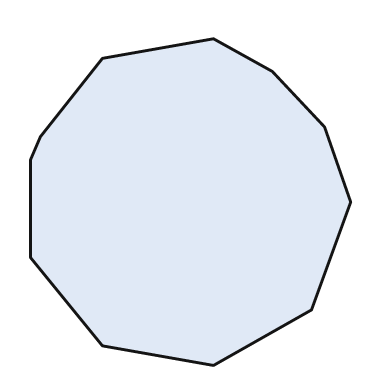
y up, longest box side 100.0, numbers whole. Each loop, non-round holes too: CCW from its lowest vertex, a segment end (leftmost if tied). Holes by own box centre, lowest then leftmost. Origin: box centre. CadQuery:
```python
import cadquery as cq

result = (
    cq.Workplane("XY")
    .moveTo(7.0, -50.0)
    .lineTo(37.0, -33.0)
    .lineTo(49.0, 0.0)
    .lineTo(41.0, 23.0)
    .lineTo(25.0, 40.0)
    .lineTo(7.0, 50.0)
    .lineTo(-27.0, 44.0)
    .lineTo(-46.0, 20.0)
    .lineTo(-49.0, 13.0)
    .lineTo(-49.0, -17.0)
    .lineTo(-27.0, -44.0)
    .close()
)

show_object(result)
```